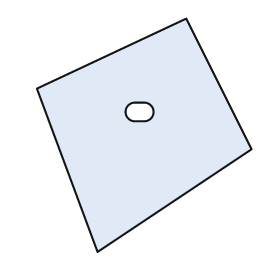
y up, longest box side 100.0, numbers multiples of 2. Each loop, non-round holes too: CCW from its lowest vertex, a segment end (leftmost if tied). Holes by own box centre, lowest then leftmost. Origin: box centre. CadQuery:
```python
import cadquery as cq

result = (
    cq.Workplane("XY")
    .moveTo(-20.0, -50.0)
    .lineTo(46.0, -6.0)
    .lineTo(18.0, 50.0)
    .lineTo(-46.0, 20.0)
    .close()
    .moveTo(-4.0, 6.0)
    .lineTo(0.0, 6.0)
    .threePointArc((4.0, 10.0), (0.0, 14.0))
    .lineTo(-4.0, 14.0)
    .threePointArc((-8.0, 10.0), (-4.0, 6.0))
    .close()
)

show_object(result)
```